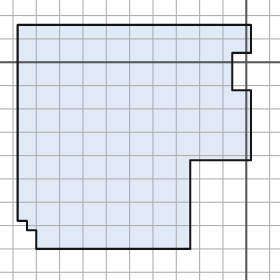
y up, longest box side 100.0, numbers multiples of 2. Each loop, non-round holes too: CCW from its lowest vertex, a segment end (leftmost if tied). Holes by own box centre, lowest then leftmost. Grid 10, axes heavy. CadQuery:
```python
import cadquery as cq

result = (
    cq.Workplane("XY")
    .moveTo(-90.0, -80.0)
    .lineTo(-24.0, -80.0)
    .lineTo(-24.0, -42.0)
    .lineTo(2.0, -42.0)
    .lineTo(2.0, -12.0)
    .lineTo(-6.0, -12.0)
    .lineTo(-6.0, 4.0)
    .lineTo(2.0, 4.0)
    .lineTo(2.0, 16.0)
    .lineTo(-98.0, 16.0)
    .lineTo(-98.0, -68.0)
    .lineTo(-94.0, -68.0)
    .lineTo(-94.0, -72.0)
    .lineTo(-90.0, -72.0)
    .close()
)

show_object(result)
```